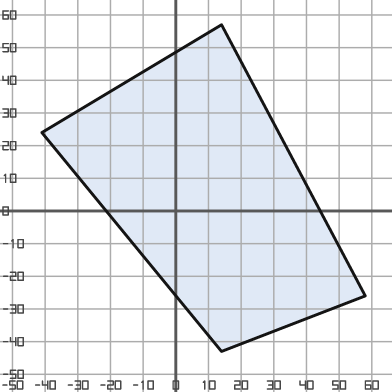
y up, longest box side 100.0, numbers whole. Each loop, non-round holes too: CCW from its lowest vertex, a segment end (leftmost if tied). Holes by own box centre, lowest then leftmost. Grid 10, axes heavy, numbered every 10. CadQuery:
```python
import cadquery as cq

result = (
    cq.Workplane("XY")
    .moveTo(14.0, -43.0)
    .lineTo(58.0, -26.0)
    .lineTo(14.0, 57.0)
    .lineTo(-41.0, 24.0)
    .close()
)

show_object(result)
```